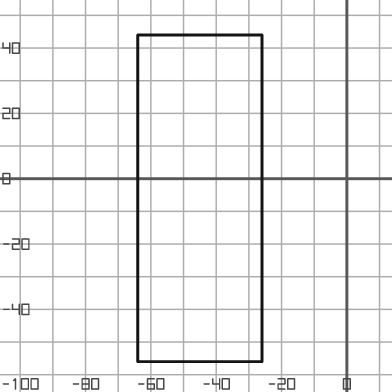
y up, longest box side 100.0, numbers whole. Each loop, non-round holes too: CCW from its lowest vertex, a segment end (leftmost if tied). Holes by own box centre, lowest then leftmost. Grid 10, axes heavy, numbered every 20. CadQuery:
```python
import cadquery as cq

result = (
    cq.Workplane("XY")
    .moveTo(-64.0, -56.0)
    .lineTo(-26.0, -56.0)
    .lineTo(-26.0, 44.0)
    .lineTo(-64.0, 44.0)
    .close()
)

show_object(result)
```